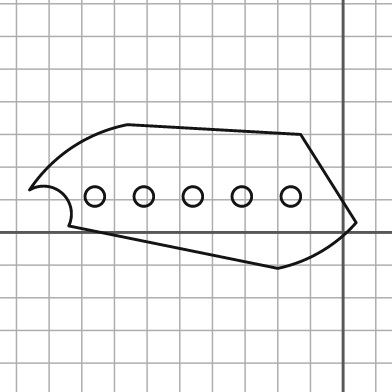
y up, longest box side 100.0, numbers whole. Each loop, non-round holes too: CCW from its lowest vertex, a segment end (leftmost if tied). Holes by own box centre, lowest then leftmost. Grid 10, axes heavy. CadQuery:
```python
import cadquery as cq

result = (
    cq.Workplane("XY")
    .moveTo(-20.0, -11.0)
    .threePointArc((-7.0, -6.0), (4.0, 3.0))
    .lineTo(-13.0, 30.0)
    .lineTo(-66.0, 33.0)
    .threePointArc((-83.0, 26.0), (-96.0, 13.0))
    .threePointArc((-86.0, 12.0), (-84.0, 2.0))
    .close()
    .moveTo(-76.0, 11.0)
    .circle(3.0)
    .moveTo(-61.0, 11.0)
    .circle(3.0)
    .moveTo(-46.0, 11.0)
    .circle(3.0)
    .moveTo(-31.0, 11.0)
    .circle(3.0)
    .moveTo(-16.0, 11.0)
    .circle(3.0)
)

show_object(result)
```